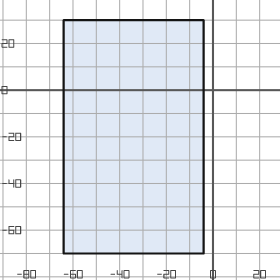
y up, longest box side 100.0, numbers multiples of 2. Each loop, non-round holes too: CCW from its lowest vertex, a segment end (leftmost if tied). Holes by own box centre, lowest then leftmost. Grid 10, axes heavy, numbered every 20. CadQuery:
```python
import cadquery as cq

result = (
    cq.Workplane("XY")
    .moveTo(-64.0, -70.0)
    .lineTo(-4.0, -70.0)
    .lineTo(-4.0, 30.0)
    .lineTo(-64.0, 30.0)
    .close()
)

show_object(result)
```